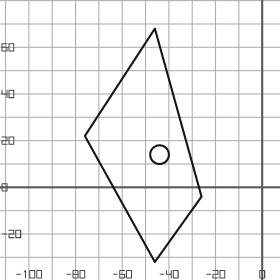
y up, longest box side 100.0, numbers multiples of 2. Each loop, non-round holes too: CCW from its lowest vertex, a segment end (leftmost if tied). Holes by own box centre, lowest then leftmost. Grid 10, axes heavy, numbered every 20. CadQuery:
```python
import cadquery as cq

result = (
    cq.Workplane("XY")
    .moveTo(-46.0, -32.0)
    .lineTo(-26.0, -4.0)
    .lineTo(-46.0, 68.0)
    .lineTo(-76.0, 22.0)
    .close()
    .moveTo(-44.0, 14.0)
    .circle(4.0)
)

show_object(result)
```